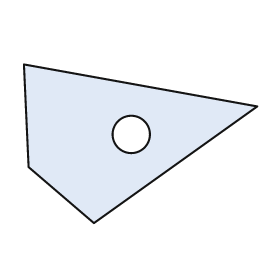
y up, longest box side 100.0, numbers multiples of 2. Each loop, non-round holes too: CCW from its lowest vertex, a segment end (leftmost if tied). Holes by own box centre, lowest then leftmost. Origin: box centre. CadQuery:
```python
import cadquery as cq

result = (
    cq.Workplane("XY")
    .moveTo(-20.0, -34.0)
    .lineTo(50.0, 16.0)
    .lineTo(-50.0, 34.0)
    .lineTo(-48.0, -10.0)
    .close()
    .moveTo(-4.0, 4.0)
    .circle(8.0)
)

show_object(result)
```